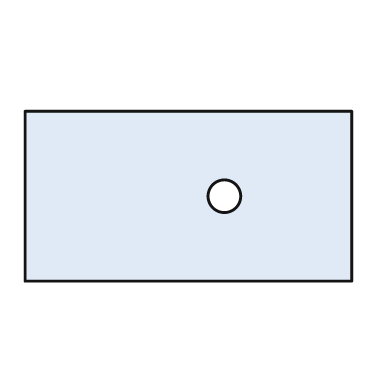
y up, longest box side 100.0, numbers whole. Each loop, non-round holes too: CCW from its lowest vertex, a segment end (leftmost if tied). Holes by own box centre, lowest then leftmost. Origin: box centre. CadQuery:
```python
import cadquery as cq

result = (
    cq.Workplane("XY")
    .moveTo(-50.0, -26.0)
    .lineTo(50.0, -26.0)
    .lineTo(50.0, 26.0)
    .lineTo(-50.0, 26.0)
    .close()
    .moveTo(11.0, 0.0)
    .circle(5.0)
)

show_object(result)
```